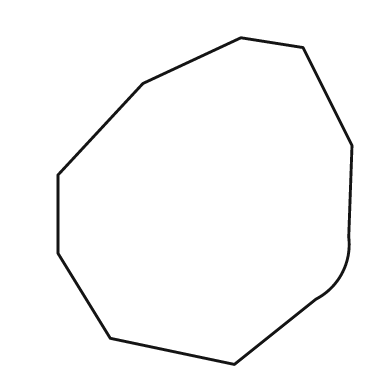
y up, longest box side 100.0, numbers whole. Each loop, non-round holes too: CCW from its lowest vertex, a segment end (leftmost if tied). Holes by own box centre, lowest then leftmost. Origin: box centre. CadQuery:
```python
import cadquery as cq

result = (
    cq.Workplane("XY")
    .moveTo(9.0, -50.0)
    .lineTo(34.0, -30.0)
    .threePointArc((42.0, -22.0), (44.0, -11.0))
    .lineTo(45.0, 17.0)
    .lineTo(30.0, 47.0)
    .lineTo(11.0, 50.0)
    .lineTo(-19.0, 36.0)
    .lineTo(-45.0, 8.0)
    .lineTo(-45.0, -16.0)
    .lineTo(-29.0, -42.0)
    .close()
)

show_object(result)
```